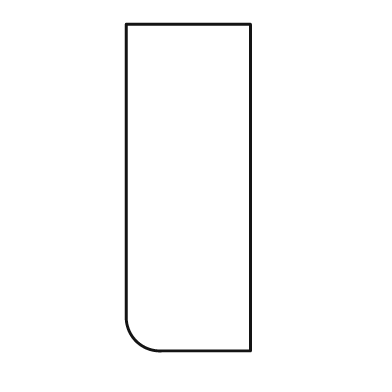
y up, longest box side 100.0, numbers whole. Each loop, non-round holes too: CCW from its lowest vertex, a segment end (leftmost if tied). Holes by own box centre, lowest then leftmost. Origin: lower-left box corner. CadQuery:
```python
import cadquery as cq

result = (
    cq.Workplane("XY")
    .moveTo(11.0, 0.0)
    .lineTo(38.0, 0.0)
    .lineTo(38.0, 100.0)
    .lineTo(0.0, 100.0)
    .lineTo(0.0, 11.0)
    .threePointArc((3.0, 3.0), (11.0, 0.0))
    .close()
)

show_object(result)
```